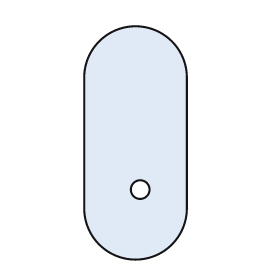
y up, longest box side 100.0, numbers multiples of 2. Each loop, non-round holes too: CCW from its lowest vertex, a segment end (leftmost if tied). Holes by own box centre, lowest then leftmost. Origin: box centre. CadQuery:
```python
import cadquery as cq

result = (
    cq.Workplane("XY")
    .moveTo(-22.0, -28.0)
    .threePointArc((0.0, -50.0), (22.0, -28.0))
    .lineTo(22.0, 28.0)
    .threePointArc((0.0, 50.0), (-22.0, 28.0))
    .close()
    .moveTo(2.0, -20.0)
    .circle(4.0)
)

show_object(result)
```